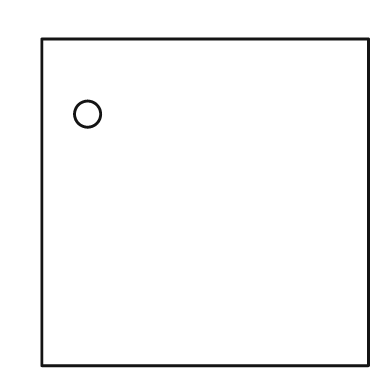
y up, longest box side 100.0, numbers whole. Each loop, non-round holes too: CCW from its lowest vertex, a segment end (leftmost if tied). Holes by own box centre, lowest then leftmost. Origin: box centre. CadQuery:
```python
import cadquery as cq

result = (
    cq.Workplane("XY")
    .moveTo(-50.0, -50.0)
    .lineTo(50.0, -50.0)
    .lineTo(50.0, 50.0)
    .lineTo(-50.0, 50.0)
    .close()
    .moveTo(-36.0, 27.0)
    .circle(4.0)
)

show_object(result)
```